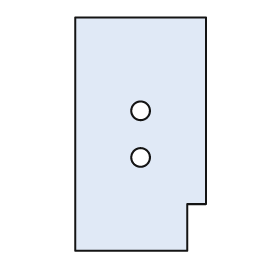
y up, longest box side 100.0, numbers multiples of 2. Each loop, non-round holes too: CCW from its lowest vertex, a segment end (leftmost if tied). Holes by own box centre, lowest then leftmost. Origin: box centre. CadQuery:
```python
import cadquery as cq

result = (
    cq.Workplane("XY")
    .moveTo(-28.0, -50.0)
    .lineTo(20.0, -50.0)
    .lineTo(20.0, -30.0)
    .lineTo(28.0, -30.0)
    .lineTo(28.0, 50.0)
    .lineTo(-28.0, 50.0)
    .close()
    .moveTo(0.0, -10.0)
    .circle(4.0)
    .moveTo(0.0, 10.0)
    .circle(4.0)
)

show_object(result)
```